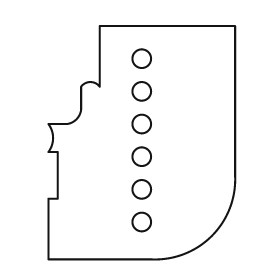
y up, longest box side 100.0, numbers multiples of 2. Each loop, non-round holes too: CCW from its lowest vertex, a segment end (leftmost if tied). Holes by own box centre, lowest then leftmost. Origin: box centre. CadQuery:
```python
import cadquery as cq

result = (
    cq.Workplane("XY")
    .moveTo(-40.0, -50.0)
    .lineTo(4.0, -50.0)
    .threePointArc((30.0, -40.0), (40.0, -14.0))
    .lineTo(40.0, 50.0)
    .lineTo(-18.0, 50.0)
    .lineTo(-18.0, 24.0)
    .threePointArc((-22.0, 26.0), (-26.0, 24.0))
    .lineTo(-26.0, 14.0)
    .threePointArc((-28.0, 10.0), (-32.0, 8.0))
    .lineTo(-40.0, 8.0)
    .threePointArc((-38.0, 2.0), (-40.0, -4.0))
    .lineTo(-36.0, -4.0)
    .lineTo(-36.0, -24.0)
    .lineTo(-40.0, -24.0)
    .close()
    .moveTo(0.0, -34.0)
    .circle(4.0)
    .moveTo(0.0, -20.0)
    .circle(4.0)
    .moveTo(0.0, -6.0)
    .circle(4.0)
    .moveTo(0.0, 8.0)
    .circle(4.0)
    .moveTo(0.0, 22.0)
    .circle(4.0)
    .moveTo(0.0, 36.0)
    .circle(4.0)
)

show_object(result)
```